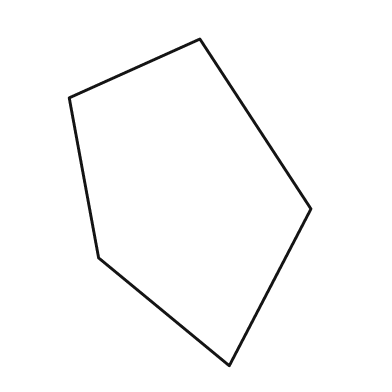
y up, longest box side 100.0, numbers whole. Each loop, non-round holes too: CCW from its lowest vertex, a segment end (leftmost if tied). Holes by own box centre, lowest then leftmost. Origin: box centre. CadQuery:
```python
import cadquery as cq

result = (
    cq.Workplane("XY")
    .moveTo(12.0, -50.0)
    .lineTo(37.0, -2.0)
    .lineTo(3.0, 50.0)
    .lineTo(-37.0, 32.0)
    .lineTo(-28.0, -17.0)
    .close()
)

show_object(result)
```